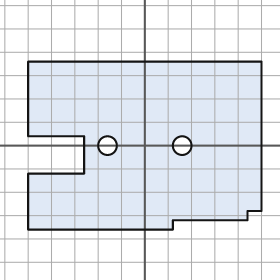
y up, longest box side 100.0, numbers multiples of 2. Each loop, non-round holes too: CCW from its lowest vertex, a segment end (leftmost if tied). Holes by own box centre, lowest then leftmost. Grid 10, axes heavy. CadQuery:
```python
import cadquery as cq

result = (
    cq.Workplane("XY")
    .moveTo(-50.0, -36.0)
    .lineTo(12.0, -36.0)
    .lineTo(12.0, -32.0)
    .lineTo(44.0, -32.0)
    .lineTo(44.0, -28.0)
    .lineTo(50.0, -28.0)
    .lineTo(50.0, 36.0)
    .lineTo(-50.0, 36.0)
    .lineTo(-50.0, 4.0)
    .lineTo(-26.0, 4.0)
    .lineTo(-26.0, -12.0)
    .lineTo(-50.0, -12.0)
    .close()
    .moveTo(-16.0, 0.0)
    .circle(4.0)
    .moveTo(16.0, 0.0)
    .circle(4.0)
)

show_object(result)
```